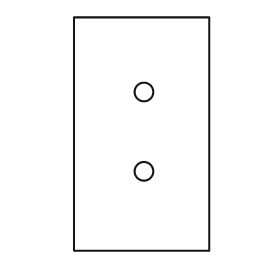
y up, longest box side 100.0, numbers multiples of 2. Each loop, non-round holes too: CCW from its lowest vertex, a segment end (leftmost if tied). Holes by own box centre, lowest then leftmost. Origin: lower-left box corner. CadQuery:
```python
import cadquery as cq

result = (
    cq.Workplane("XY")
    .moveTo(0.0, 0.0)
    .lineTo(58.0, 0.0)
    .lineTo(58.0, 100.0)
    .lineTo(0.0, 100.0)
    .close()
    .moveTo(30.0, 34.0)
    .circle(4.0)
    .moveTo(30.0, 68.0)
    .circle(4.0)
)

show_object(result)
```